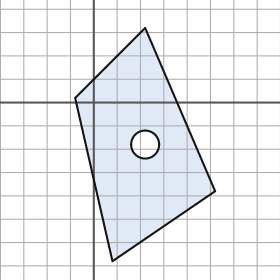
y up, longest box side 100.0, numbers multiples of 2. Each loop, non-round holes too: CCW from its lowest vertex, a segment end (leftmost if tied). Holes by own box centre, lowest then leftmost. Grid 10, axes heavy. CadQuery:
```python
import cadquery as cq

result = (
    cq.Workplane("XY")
    .moveTo(8.0, -68.0)
    .lineTo(52.0, -38.0)
    .lineTo(22.0, 32.0)
    .lineTo(-8.0, 2.0)
    .close()
    .moveTo(22.0, -18.0)
    .circle(6.0)
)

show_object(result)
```